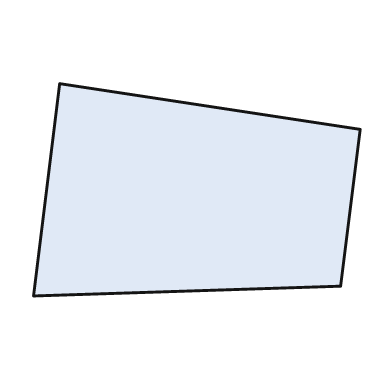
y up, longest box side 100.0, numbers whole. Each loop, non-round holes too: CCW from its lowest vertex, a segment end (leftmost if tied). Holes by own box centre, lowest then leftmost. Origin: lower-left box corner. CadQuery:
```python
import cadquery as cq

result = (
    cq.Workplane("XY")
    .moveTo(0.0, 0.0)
    .lineTo(94.0, 3.0)
    .lineTo(100.0, 51.0)
    .lineTo(8.0, 65.0)
    .close()
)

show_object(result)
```